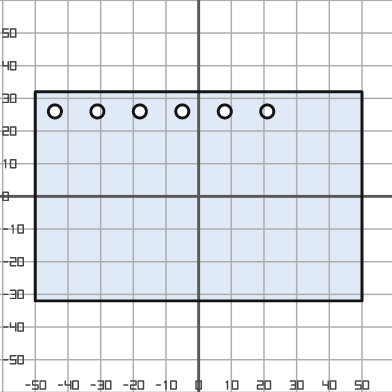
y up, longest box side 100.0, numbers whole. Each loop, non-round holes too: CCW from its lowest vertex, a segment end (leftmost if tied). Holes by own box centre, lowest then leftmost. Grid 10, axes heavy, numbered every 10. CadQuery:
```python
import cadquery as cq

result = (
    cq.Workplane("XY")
    .moveTo(-50.0, -32.0)
    .lineTo(50.0, -32.0)
    .lineTo(50.0, 32.0)
    .lineTo(-50.0, 32.0)
    .close()
    .moveTo(-44.0, 26.0)
    .circle(2.0)
    .moveTo(-31.0, 26.0)
    .circle(2.0)
    .moveTo(-18.0, 26.0)
    .circle(2.0)
    .moveTo(-5.0, 26.0)
    .circle(2.0)
    .moveTo(8.0, 26.0)
    .circle(2.0)
    .moveTo(21.0, 26.0)
    .circle(2.0)
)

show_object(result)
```